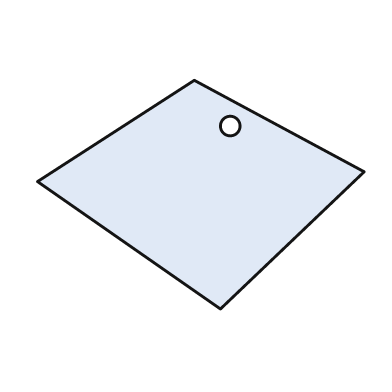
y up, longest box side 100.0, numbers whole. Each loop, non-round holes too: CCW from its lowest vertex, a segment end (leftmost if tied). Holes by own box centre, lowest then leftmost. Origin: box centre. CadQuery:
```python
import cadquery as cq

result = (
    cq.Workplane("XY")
    .moveTo(6.0, -35.0)
    .lineTo(50.0, 7.0)
    .lineTo(-2.0, 35.0)
    .lineTo(-50.0, 4.0)
    .close()
    .moveTo(9.0, 21.0)
    .circle(3.0)
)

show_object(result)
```